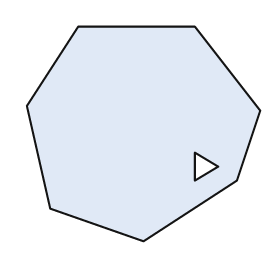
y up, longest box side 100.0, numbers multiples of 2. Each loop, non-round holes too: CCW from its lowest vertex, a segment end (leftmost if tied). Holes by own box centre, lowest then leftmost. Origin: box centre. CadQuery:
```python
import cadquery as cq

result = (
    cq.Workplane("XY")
    .moveTo(0.0, -46.0)
    .lineTo(40.0, -20.0)
    .lineTo(50.0, 10.0)
    .lineTo(22.0, 46.0)
    .lineTo(-28.0, 46.0)
    .lineTo(-50.0, 12.0)
    .lineTo(-40.0, -32.0)
    .close()
    .moveTo(22.0, -20.0)
    .lineTo(32.0, -14.0)
    .lineTo(22.0, -8.0)
    .close()
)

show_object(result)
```